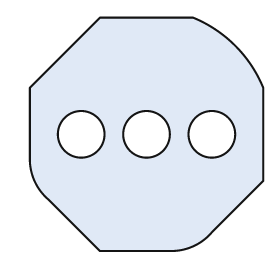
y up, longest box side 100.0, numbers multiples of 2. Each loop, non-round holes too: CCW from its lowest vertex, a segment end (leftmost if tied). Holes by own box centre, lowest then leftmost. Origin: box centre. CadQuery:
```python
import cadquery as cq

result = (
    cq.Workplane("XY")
    .moveTo(-20.0, -50.0)
    .lineTo(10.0, -50.0)
    .threePointArc((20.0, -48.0), (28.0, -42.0))
    .lineTo(50.0, -20.0)
    .lineTo(50.0, 20.0)
    .threePointArc((38.0, 38.0), (20.0, 50.0))
    .lineTo(-20.0, 50.0)
    .lineTo(-50.0, 20.0)
    .lineTo(-50.0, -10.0)
    .threePointArc((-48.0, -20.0), (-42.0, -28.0))
    .close()
    .moveTo(-28.0, 0.0)
    .circle(10.0)
    .moveTo(0.0, 0.0)
    .circle(10.0)
    .moveTo(28.0, 0.0)
    .circle(10.0)
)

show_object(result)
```